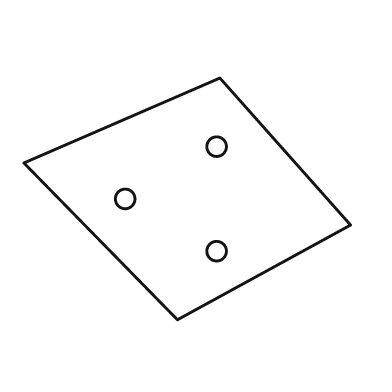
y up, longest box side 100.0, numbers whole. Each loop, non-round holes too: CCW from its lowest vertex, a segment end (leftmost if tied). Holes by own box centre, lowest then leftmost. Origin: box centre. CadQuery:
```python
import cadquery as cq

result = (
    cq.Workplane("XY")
    .moveTo(-3.0, -37.0)
    .lineTo(50.0, -8.0)
    .lineTo(10.0, 37.0)
    .lineTo(-50.0, 11.0)
    .close()
    .moveTo(9.0, -16.0)
    .circle(3.0)
    .moveTo(-19.0, 0.0)
    .circle(3.0)
    .moveTo(9.0, 16.0)
    .circle(3.0)
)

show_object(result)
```